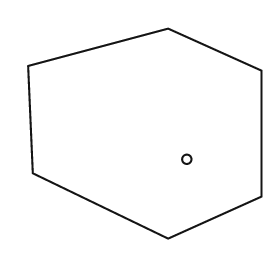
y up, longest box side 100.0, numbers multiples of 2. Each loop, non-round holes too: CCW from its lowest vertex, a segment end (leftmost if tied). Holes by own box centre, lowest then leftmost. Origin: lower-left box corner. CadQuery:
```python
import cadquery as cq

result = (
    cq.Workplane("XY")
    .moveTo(60.0, 0.0)
    .lineTo(100.0, 18.0)
    .lineTo(100.0, 72.0)
    .lineTo(60.0, 90.0)
    .lineTo(0.0, 74.0)
    .lineTo(2.0, 28.0)
    .close()
    .moveTo(68.0, 34.0)
    .circle(2.0)
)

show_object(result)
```